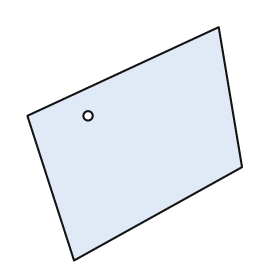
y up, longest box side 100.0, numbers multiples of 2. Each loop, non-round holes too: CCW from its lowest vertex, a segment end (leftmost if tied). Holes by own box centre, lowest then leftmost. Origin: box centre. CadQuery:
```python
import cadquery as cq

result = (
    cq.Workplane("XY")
    .moveTo(-26.0, -50.0)
    .lineTo(46.0, -10.0)
    .lineTo(36.0, 50.0)
    .lineTo(-46.0, 12.0)
    .close()
    .moveTo(-20.0, 12.0)
    .circle(2.0)
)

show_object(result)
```